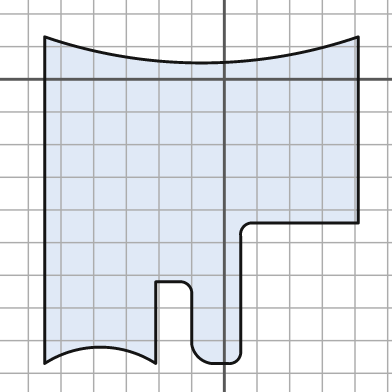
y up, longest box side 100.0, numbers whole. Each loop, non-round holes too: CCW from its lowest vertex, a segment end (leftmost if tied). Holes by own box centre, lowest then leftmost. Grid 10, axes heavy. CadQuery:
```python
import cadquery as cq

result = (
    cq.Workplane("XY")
    .moveTo(-55.0, -87.0)
    .threePointArc((-38.0, -82.0), (-21.0, -87.0))
    .lineTo(-21.0, -62.0)
    .lineTo(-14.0, -62.0)
    .threePointArc((-11.0, -63.0), (-10.0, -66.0))
    .lineTo(-10.0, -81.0)
    .threePointArc((-8.0, -85.0), (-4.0, -87.0))
    .lineTo(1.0, -87.0)
    .threePointArc((4.0, -86.0), (5.0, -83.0))
    .lineTo(5.0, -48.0)
    .threePointArc((6.0, -45.0), (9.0, -44.0))
    .lineTo(41.0, -44.0)
    .lineTo(41.0, 13.0)
    .threePointArc((-7.0, 5.0), (-55.0, 13.0))
    .close()
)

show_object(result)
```